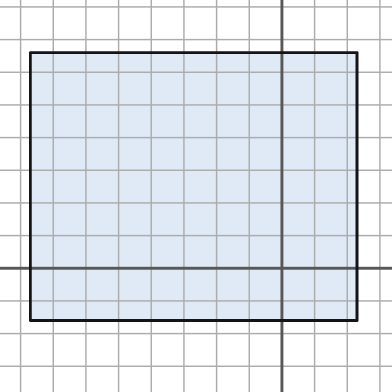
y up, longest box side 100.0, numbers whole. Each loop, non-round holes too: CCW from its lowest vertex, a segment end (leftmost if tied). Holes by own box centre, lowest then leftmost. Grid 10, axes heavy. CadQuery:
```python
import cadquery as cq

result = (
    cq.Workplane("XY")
    .moveTo(-77.0, -16.0)
    .lineTo(23.0, -16.0)
    .lineTo(23.0, 66.0)
    .lineTo(-77.0, 66.0)
    .close()
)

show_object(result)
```